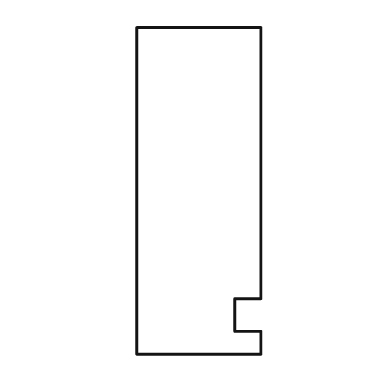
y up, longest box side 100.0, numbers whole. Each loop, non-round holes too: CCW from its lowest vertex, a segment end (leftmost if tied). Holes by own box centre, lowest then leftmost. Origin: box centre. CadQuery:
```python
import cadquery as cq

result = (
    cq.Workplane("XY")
    .moveTo(-19.0, -50.0)
    .lineTo(19.0, -50.0)
    .lineTo(19.0, -43.0)
    .lineTo(11.0, -43.0)
    .lineTo(11.0, -33.0)
    .lineTo(19.0, -33.0)
    .lineTo(19.0, 50.0)
    .lineTo(-19.0, 50.0)
    .close()
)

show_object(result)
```